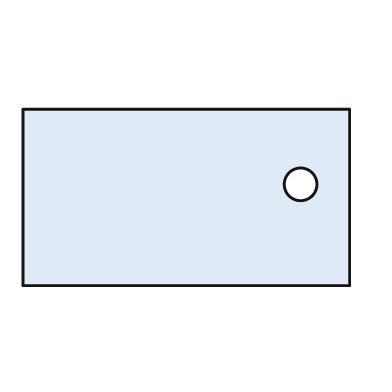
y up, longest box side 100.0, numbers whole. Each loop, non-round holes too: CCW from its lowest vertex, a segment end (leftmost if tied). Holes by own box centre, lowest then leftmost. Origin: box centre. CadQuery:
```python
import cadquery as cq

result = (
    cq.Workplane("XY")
    .moveTo(-50.0, -27.0)
    .lineTo(50.0, -27.0)
    .lineTo(50.0, 27.0)
    .lineTo(-50.0, 27.0)
    .close()
    .moveTo(35.0, 4.0)
    .circle(5.0)
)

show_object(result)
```